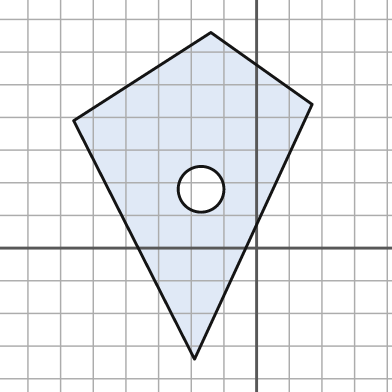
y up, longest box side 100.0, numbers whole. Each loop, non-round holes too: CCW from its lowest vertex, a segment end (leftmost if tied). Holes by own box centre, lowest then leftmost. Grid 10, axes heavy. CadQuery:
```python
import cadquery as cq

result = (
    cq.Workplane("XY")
    .moveTo(-19.0, -34.0)
    .lineTo(17.0, 44.0)
    .lineTo(-14.0, 66.0)
    .lineTo(-56.0, 39.0)
    .close()
    .moveTo(-17.0, 18.0)
    .circle(7.0)
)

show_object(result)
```